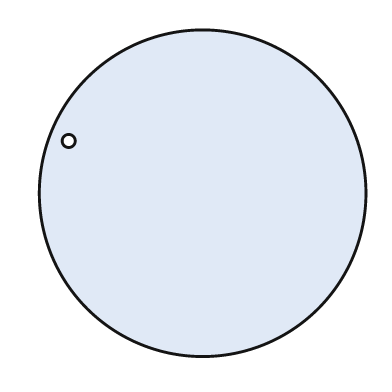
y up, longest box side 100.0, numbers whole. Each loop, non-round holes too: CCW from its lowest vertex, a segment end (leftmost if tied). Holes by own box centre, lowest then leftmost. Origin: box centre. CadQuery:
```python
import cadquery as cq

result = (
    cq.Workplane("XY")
    .moveTo(0.0, 0.0)
    .circle(50.0)
    .moveTo(-41.0, 16.0)
    .circle(2.0)
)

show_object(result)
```